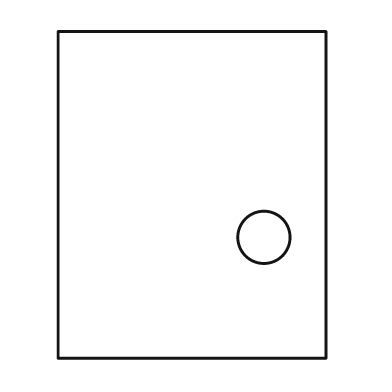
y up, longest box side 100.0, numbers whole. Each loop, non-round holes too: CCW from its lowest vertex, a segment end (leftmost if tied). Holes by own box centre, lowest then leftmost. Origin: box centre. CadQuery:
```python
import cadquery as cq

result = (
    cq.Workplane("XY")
    .moveTo(-41.0, -50.0)
    .lineTo(41.0, -50.0)
    .lineTo(41.0, 50.0)
    .lineTo(-41.0, 50.0)
    .close()
    .moveTo(22.0, -13.0)
    .circle(8.0)
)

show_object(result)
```